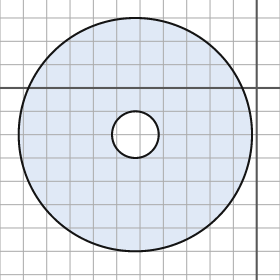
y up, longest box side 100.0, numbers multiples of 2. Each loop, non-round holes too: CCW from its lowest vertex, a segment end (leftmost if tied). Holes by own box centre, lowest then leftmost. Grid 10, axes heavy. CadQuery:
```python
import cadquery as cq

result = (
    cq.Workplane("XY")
    .moveTo(-52.0, -20.0)
    .circle(50.0)
    .moveTo(-52.0, -20.0)
    .circle(10.0)
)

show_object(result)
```